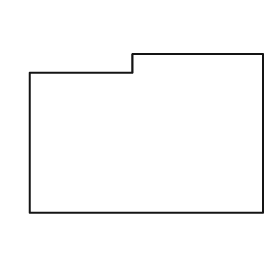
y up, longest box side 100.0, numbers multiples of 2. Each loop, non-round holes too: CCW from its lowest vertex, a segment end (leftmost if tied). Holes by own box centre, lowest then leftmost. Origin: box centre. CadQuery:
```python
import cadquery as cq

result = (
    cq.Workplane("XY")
    .moveTo(-50.0, -34.0)
    .lineTo(50.0, -34.0)
    .lineTo(50.0, 34.0)
    .lineTo(-6.0, 34.0)
    .lineTo(-6.0, 26.0)
    .lineTo(-50.0, 26.0)
    .close()
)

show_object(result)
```